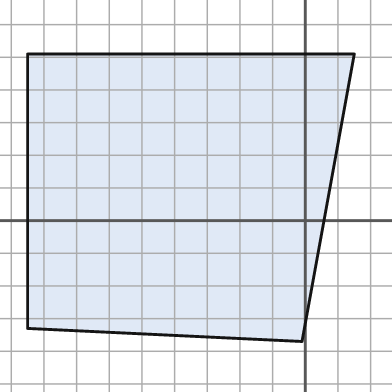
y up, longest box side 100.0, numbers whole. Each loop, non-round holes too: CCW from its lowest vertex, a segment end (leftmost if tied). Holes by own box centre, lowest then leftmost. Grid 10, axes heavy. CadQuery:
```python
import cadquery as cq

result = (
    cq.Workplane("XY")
    .moveTo(-1.0, -37.0)
    .lineTo(15.0, 51.0)
    .lineTo(-85.0, 51.0)
    .lineTo(-85.0, -33.0)
    .close()
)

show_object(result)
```